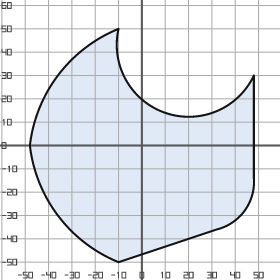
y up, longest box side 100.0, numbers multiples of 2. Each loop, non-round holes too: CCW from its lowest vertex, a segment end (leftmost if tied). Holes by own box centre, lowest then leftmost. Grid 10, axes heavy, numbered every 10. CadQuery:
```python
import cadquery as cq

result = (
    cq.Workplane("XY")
    .moveTo(-10.0, -50.0)
    .lineTo(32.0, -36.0)
    .threePointArc((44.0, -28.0), (48.0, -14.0))
    .lineTo(48.0, 30.0)
    .threePointArc((10.0, 14.0), (-10.0, 50.0))
    .threePointArc((-36.0, 30.0), (-48.0, 0.0))
    .threePointArc((-36.0, -30.0), (-10.0, -50.0))
    .close()
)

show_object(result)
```